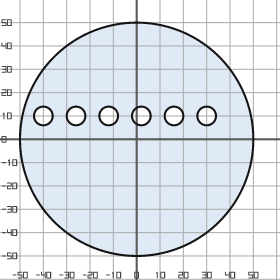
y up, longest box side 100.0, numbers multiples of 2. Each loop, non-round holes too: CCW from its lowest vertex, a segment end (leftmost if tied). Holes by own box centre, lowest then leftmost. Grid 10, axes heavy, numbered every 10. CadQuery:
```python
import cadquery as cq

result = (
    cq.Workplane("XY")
    .moveTo(0.0, 0.0)
    .circle(50.0)
    .moveTo(-40.0, 10.0)
    .circle(4.0)
    .moveTo(-26.0, 10.0)
    .circle(4.0)
    .moveTo(-12.0, 10.0)
    .circle(4.0)
    .moveTo(2.0, 10.0)
    .circle(4.0)
    .moveTo(16.0, 10.0)
    .circle(4.0)
    .moveTo(30.0, 10.0)
    .circle(4.0)
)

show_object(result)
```